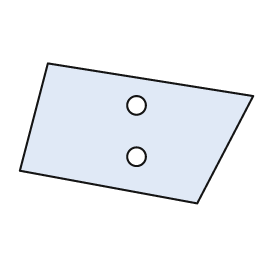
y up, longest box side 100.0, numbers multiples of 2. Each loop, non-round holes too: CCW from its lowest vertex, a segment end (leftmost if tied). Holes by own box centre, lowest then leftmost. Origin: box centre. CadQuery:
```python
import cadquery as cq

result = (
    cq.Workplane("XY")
    .moveTo(26.0, -30.0)
    .lineTo(50.0, 16.0)
    .lineTo(-38.0, 30.0)
    .lineTo(-50.0, -16.0)
    .close()
    .moveTo(0.0, -10.0)
    .circle(4.0)
    .moveTo(0.0, 12.0)
    .circle(4.0)
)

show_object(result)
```